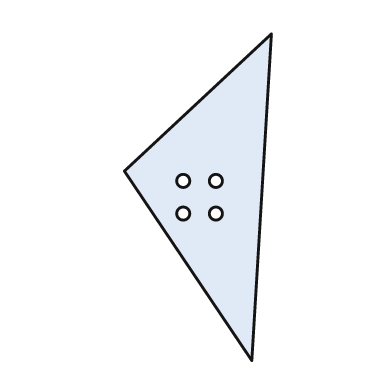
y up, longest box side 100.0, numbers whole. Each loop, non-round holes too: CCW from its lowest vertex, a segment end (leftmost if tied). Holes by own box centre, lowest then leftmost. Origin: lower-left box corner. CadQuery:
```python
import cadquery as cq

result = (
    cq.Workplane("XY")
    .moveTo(39.0, 0.0)
    .lineTo(45.0, 100.0)
    .lineTo(0.0, 58.0)
    .close()
    .moveTo(18.0, 45.0)
    .circle(2.0)
    .moveTo(28.0, 45.0)
    .circle(2.0)
    .moveTo(18.0, 55.0)
    .circle(2.0)
    .moveTo(28.0, 55.0)
    .circle(2.0)
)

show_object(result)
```